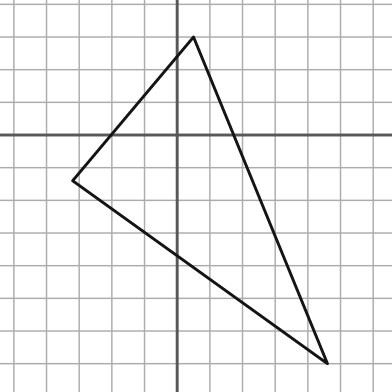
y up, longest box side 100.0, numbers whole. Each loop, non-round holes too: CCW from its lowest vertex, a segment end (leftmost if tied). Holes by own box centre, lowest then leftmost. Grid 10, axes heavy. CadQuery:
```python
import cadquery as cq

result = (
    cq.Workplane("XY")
    .moveTo(46.0, -70.0)
    .lineTo(5.0, 30.0)
    .lineTo(-32.0, -14.0)
    .close()
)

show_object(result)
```